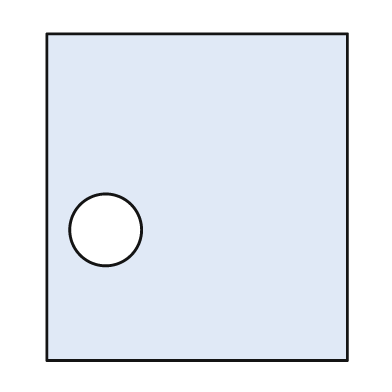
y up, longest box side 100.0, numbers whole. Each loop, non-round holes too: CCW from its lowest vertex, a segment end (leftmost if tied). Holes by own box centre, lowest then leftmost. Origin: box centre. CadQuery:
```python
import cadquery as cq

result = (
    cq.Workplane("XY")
    .moveTo(-46.0, -50.0)
    .lineTo(46.0, -50.0)
    .lineTo(46.0, 50.0)
    .lineTo(-46.0, 50.0)
    .close()
    .moveTo(-28.0, -10.0)
    .circle(11.0)
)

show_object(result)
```